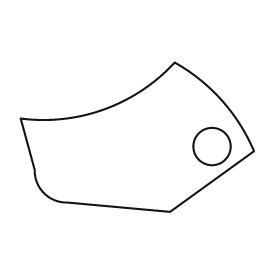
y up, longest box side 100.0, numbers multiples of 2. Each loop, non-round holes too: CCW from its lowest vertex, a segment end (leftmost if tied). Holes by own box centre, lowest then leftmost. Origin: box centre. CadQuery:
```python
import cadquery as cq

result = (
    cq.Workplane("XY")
    .moveTo(14.0, -32.0)
    .lineTo(50.0, -6.0)
    .threePointArc((36.0, 16.0), (16.0, 32.0))
    .threePointArc((-14.0, 12.0), (-50.0, 8.0))
    .lineTo(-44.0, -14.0)
    .threePointArc((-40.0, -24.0), (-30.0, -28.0))
    .close()
    .moveTo(32.0, -4.0)
    .circle(8.0)
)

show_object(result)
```